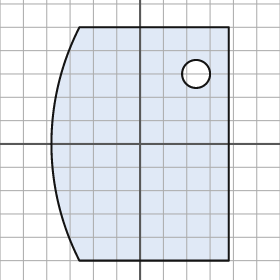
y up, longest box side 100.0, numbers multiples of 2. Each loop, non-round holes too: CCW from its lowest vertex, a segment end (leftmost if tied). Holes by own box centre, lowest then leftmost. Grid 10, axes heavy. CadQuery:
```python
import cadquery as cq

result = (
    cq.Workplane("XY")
    .moveTo(-26.0, -50.0)
    .lineTo(38.0, -50.0)
    .lineTo(38.0, 50.0)
    .lineTo(-26.0, 50.0)
    .threePointArc((-38.0, 0.0), (-26.0, -50.0))
    .close()
    .moveTo(24.0, 30.0)
    .circle(6.0)
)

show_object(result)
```